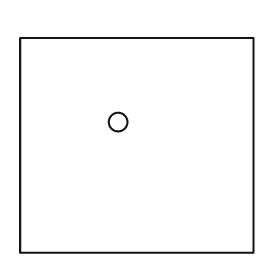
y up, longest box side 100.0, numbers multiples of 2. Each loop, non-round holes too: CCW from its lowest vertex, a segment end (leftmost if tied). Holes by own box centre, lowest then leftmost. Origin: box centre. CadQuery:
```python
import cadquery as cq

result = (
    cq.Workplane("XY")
    .moveTo(-50.0, -46.0)
    .lineTo(50.0, -46.0)
    .lineTo(50.0, 46.0)
    .lineTo(-50.0, 46.0)
    .close()
    .moveTo(-8.0, 10.0)
    .circle(4.0)
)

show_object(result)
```